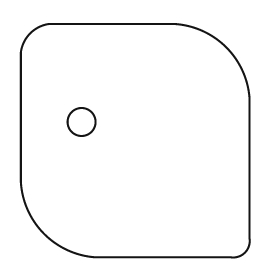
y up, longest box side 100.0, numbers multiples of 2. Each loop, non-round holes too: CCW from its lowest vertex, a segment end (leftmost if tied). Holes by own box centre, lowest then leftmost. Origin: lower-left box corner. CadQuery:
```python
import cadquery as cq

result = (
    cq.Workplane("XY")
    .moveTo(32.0, 0.0)
    .lineTo(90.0, 0.0)
    .threePointArc((96.0, 2.0), (98.0, 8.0))
    .lineTo(98.0, 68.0)
    .threePointArc((88.0, 90.0), (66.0, 100.0))
    .lineTo(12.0, 100.0)
    .threePointArc((4.0, 96.0), (0.0, 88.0))
    .lineTo(0.0, 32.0)
    .threePointArc((10.0, 10.0), (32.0, 0.0))
    .close()
    .moveTo(26.0, 58.0)
    .circle(6.0)
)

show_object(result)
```